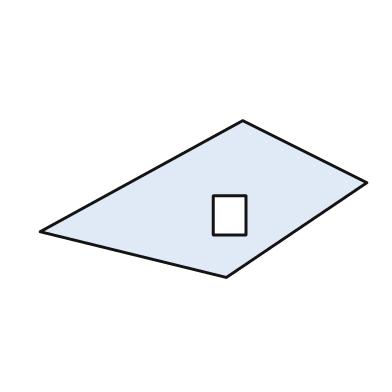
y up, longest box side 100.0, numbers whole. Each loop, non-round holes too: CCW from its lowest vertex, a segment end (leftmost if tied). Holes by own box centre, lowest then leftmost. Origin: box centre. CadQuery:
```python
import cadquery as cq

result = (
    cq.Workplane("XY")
    .moveTo(7.0, -24.0)
    .lineTo(50.0, 5.0)
    .lineTo(12.0, 24.0)
    .lineTo(-50.0, -10.0)
    .close()
    .moveTo(3.0, -11.0)
    .lineTo(13.0, -11.0)
    .lineTo(13.0, 1.0)
    .lineTo(3.0, 1.0)
    .close()
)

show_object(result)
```